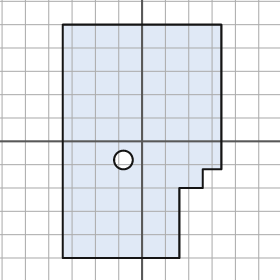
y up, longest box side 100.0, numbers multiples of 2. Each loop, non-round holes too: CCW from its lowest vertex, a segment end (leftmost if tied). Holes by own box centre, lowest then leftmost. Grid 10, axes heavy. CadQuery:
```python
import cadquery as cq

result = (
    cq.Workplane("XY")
    .moveTo(-34.0, -50.0)
    .lineTo(16.0, -50.0)
    .lineTo(16.0, -20.0)
    .lineTo(26.0, -20.0)
    .lineTo(26.0, -12.0)
    .lineTo(34.0, -12.0)
    .lineTo(34.0, 50.0)
    .lineTo(-34.0, 50.0)
    .close()
    .moveTo(-8.0, -8.0)
    .circle(4.0)
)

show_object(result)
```